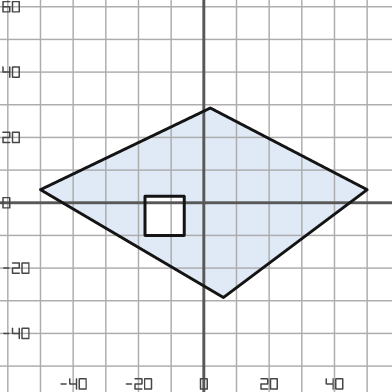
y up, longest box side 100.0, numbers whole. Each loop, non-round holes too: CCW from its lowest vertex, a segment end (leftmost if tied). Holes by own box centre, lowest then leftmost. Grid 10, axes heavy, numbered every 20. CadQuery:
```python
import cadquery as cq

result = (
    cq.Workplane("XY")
    .moveTo(6.0, -29.0)
    .lineTo(50.0, 4.0)
    .lineTo(2.0, 29.0)
    .lineTo(-50.0, 4.0)
    .close()
    .moveTo(-18.0, -10.0)
    .lineTo(-6.0, -10.0)
    .lineTo(-6.0, 2.0)
    .lineTo(-18.0, 2.0)
    .close()
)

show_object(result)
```